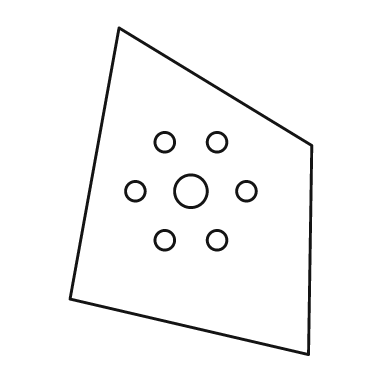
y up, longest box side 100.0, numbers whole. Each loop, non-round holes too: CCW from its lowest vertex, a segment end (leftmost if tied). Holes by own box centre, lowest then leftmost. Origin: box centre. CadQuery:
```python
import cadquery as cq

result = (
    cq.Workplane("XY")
    .moveTo(36.0, -50.0)
    .lineTo(37.0, 14.0)
    .lineTo(-22.0, 50.0)
    .lineTo(-37.0, -33.0)
    .close()
    .moveTo(-8.0, -15.0)
    .circle(3.0)
    .moveTo(8.0, -15.0)
    .circle(3.0)
    .moveTo(-17.0, 0.0)
    .circle(3.0)
    .moveTo(0.0, 0.0)
    .circle(5.0)
    .moveTo(17.0, 0.0)
    .circle(3.0)
    .moveTo(-8.0, 15.0)
    .circle(3.0)
    .moveTo(8.0, 15.0)
    .circle(3.0)
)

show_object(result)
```